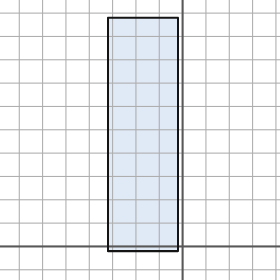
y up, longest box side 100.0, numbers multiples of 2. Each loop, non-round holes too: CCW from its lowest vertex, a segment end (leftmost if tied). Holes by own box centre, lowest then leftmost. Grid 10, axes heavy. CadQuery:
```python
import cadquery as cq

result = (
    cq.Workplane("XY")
    .moveTo(-32.0, -2.0)
    .lineTo(-2.0, -2.0)
    .lineTo(-2.0, 98.0)
    .lineTo(-32.0, 98.0)
    .close()
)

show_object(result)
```